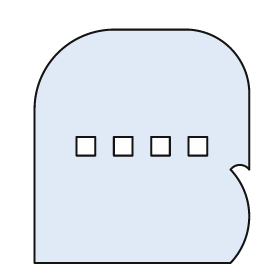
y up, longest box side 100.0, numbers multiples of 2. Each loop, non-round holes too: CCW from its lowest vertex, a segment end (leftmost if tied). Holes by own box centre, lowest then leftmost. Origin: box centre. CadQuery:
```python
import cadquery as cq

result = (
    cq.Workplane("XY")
    .moveTo(-46.0, -50.0)
    .lineTo(38.0, -50.0)
    .threePointArc((46.0, -30.0), (38.0, -10.0))
    .threePointArc((42.0, -8.0), (46.0, -10.0))
    .lineTo(46.0, 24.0)
    .threePointArc((38.0, 42.0), (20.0, 50.0))
    .lineTo(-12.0, 50.0)
    .threePointArc((-36.0, 40.0), (-46.0, 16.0))
    .close()
    .moveTo(-28.0, -4.0)
    .lineTo(-20.0, -4.0)
    .lineTo(-20.0, 4.0)
    .lineTo(-28.0, 4.0)
    .close()
    .moveTo(-12.0, -4.0)
    .lineTo(-4.0, -4.0)
    .lineTo(-4.0, 4.0)
    .lineTo(-12.0, 4.0)
    .close()
    .moveTo(4.0, -4.0)
    .lineTo(12.0, -4.0)
    .lineTo(12.0, 4.0)
    .lineTo(4.0, 4.0)
    .close()
    .moveTo(20.0, -4.0)
    .lineTo(28.0, -4.0)
    .lineTo(28.0, 4.0)
    .lineTo(20.0, 4.0)
    .close()
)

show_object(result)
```